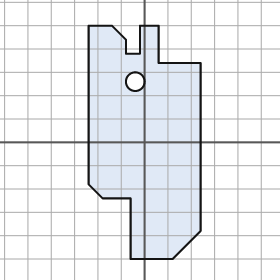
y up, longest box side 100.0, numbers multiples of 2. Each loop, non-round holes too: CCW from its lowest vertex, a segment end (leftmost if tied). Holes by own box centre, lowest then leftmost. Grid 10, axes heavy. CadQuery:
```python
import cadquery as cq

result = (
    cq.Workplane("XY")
    .moveTo(-6.0, -50.0)
    .lineTo(12.0, -50.0)
    .lineTo(24.0, -38.0)
    .lineTo(24.0, 34.0)
    .lineTo(6.0, 34.0)
    .lineTo(6.0, 50.0)
    .lineTo(-2.0, 50.0)
    .lineTo(-2.0, 38.0)
    .lineTo(-8.0, 38.0)
    .lineTo(-8.0, 44.0)
    .lineTo(-14.0, 50.0)
    .lineTo(-24.0, 50.0)
    .lineTo(-24.0, -18.0)
    .lineTo(-18.0, -24.0)
    .lineTo(-6.0, -24.0)
    .close()
    .moveTo(-4.0, 26.0)
    .circle(4.0)
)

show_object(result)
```